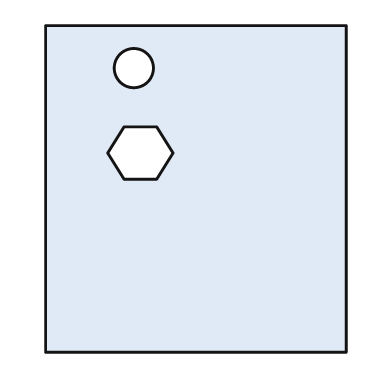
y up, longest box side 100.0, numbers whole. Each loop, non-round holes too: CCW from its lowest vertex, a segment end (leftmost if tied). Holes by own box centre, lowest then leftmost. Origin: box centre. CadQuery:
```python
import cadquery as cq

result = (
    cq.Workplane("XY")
    .moveTo(-46.0, -50.0)
    .lineTo(46.0, -50.0)
    .lineTo(46.0, 50.0)
    .lineTo(-46.0, 50.0)
    .close()
    .moveTo(-22.0, 3.0)
    .lineTo(-12.0, 3.0)
    .lineTo(-7.0, 11.0)
    .lineTo(-12.0, 19.0)
    .lineTo(-22.0, 19.0)
    .lineTo(-27.0, 11.0)
    .close()
    .moveTo(-19.0, 37.0)
    .circle(6.0)
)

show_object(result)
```